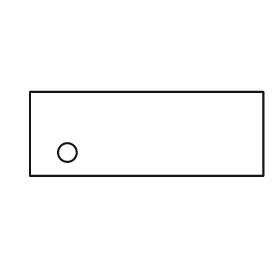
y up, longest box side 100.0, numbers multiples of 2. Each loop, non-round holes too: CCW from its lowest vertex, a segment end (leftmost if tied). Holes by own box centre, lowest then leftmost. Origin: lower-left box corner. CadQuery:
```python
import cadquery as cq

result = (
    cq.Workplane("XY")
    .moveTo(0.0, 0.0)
    .lineTo(100.0, 0.0)
    .lineTo(100.0, 36.0)
    .lineTo(0.0, 36.0)
    .close()
    .moveTo(16.0, 10.0)
    .circle(4.0)
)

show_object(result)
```